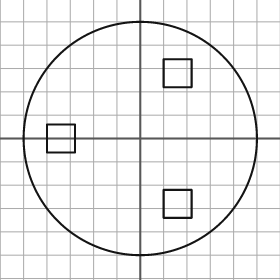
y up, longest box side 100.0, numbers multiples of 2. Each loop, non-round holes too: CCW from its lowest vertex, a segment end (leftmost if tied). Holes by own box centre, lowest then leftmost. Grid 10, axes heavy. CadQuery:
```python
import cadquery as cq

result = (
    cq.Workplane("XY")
    .moveTo(0.0, 0.0)
    .circle(50.0)
    .moveTo(10.0, -34.0)
    .lineTo(22.0, -34.0)
    .lineTo(22.0, -22.0)
    .lineTo(10.0, -22.0)
    .close()
    .moveTo(-40.0, -6.0)
    .lineTo(-28.0, -6.0)
    .lineTo(-28.0, 6.0)
    .lineTo(-40.0, 6.0)
    .close()
    .moveTo(10.0, 22.0)
    .lineTo(22.0, 22.0)
    .lineTo(22.0, 34.0)
    .lineTo(10.0, 34.0)
    .close()
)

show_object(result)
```